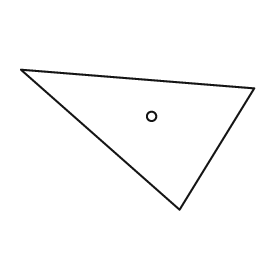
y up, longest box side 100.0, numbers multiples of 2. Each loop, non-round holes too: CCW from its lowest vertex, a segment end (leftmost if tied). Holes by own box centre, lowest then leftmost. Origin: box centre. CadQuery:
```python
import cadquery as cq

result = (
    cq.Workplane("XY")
    .moveTo(18.0, -30.0)
    .lineTo(50.0, 22.0)
    .lineTo(-50.0, 30.0)
    .close()
    .moveTo(6.0, 10.0)
    .circle(2.0)
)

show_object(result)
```